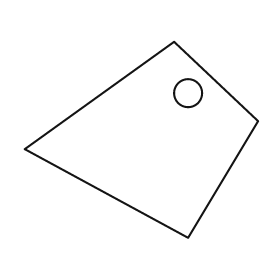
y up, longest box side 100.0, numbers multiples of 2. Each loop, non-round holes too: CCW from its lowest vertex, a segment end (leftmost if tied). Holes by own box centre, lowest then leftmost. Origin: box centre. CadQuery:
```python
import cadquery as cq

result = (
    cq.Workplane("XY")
    .moveTo(20.0, -42.0)
    .lineTo(50.0, 8.0)
    .lineTo(14.0, 42.0)
    .lineTo(-50.0, -4.0)
    .close()
    .moveTo(20.0, 20.0)
    .circle(6.0)
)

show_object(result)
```